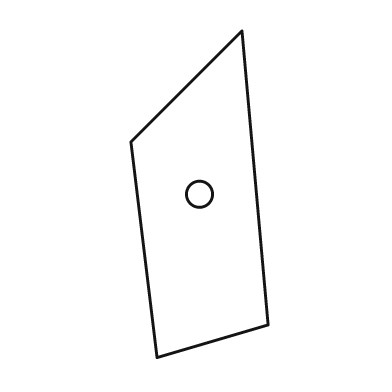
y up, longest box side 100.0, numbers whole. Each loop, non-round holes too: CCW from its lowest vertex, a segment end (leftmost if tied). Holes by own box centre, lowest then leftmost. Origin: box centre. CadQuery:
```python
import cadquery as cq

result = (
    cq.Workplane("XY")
    .moveTo(-13.0, -50.0)
    .lineTo(21.0, -40.0)
    .lineTo(13.0, 50.0)
    .lineTo(-21.0, 16.0)
    .close()
    .moveTo(0.0, 0.0)
    .circle(4.0)
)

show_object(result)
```